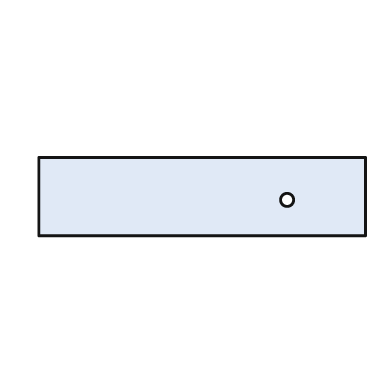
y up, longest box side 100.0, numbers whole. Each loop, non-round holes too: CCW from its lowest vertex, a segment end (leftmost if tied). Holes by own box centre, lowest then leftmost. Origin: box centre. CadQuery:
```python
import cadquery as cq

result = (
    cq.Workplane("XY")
    .moveTo(-50.0, -12.0)
    .lineTo(50.0, -12.0)
    .lineTo(50.0, 12.0)
    .lineTo(-50.0, 12.0)
    .close()
    .moveTo(26.0, -1.0)
    .circle(2.0)
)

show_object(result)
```